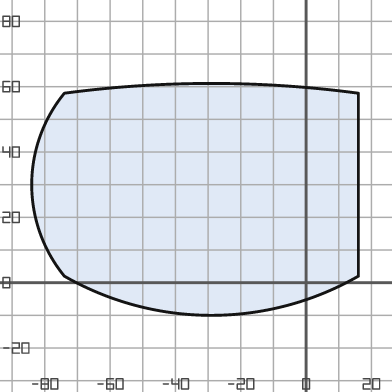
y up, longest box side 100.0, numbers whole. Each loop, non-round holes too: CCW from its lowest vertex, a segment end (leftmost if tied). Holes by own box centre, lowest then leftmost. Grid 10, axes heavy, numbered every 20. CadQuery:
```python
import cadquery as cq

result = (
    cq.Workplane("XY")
    .moveTo(-74.0, 2.0)
    .threePointArc((-29.0, -10.0), (16.0, 2.0))
    .lineTo(16.0, 58.0)
    .threePointArc((-29.0, 61.0), (-74.0, 58.0))
    .threePointArc((-84.0, 30.0), (-74.0, 2.0))
    .close()
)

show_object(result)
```